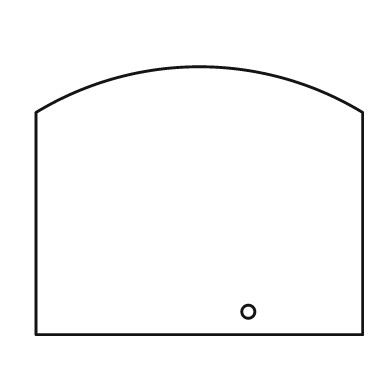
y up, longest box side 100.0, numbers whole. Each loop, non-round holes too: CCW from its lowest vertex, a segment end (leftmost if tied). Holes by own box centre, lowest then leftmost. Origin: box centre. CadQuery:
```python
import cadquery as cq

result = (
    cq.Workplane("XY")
    .moveTo(-50.0, -41.0)
    .lineTo(50.0, -41.0)
    .lineTo(50.0, 27.0)
    .threePointArc((0.0, 41.0), (-50.0, 27.0))
    .close()
    .moveTo(15.0, -34.0)
    .circle(2.0)
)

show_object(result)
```